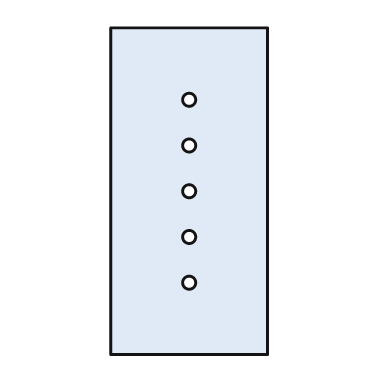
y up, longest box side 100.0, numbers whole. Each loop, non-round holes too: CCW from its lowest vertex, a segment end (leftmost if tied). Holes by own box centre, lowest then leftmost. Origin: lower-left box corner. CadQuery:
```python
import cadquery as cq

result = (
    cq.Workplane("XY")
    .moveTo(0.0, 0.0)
    .lineTo(48.0, 0.0)
    .lineTo(48.0, 100.0)
    .lineTo(0.0, 100.0)
    .close()
    .moveTo(24.0, 22.0)
    .circle(2.0)
    .moveTo(24.0, 36.0)
    .circle(2.0)
    .moveTo(24.0, 50.0)
    .circle(2.0)
    .moveTo(24.0, 64.0)
    .circle(2.0)
    .moveTo(24.0, 78.0)
    .circle(2.0)
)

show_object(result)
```